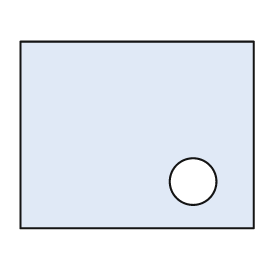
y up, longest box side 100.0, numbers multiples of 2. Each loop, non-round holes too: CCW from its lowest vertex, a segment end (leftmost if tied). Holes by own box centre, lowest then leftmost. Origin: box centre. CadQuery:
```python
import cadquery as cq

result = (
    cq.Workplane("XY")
    .moveTo(-50.0, -40.0)
    .lineTo(50.0, -40.0)
    .lineTo(50.0, 40.0)
    .lineTo(-50.0, 40.0)
    .close()
    .moveTo(24.0, -20.0)
    .circle(10.0)
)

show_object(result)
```